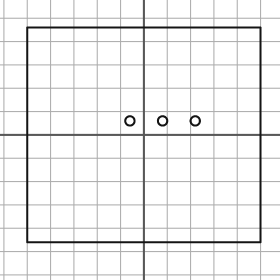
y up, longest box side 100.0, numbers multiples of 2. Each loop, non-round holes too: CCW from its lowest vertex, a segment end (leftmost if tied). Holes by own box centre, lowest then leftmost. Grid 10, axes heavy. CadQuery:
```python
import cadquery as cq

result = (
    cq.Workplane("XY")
    .moveTo(-50.0, -46.0)
    .lineTo(50.0, -46.0)
    .lineTo(50.0, 46.0)
    .lineTo(-50.0, 46.0)
    .close()
    .moveTo(-6.0, 6.0)
    .circle(2.0)
    .moveTo(8.0, 6.0)
    .circle(2.0)
    .moveTo(22.0, 6.0)
    .circle(2.0)
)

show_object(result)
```